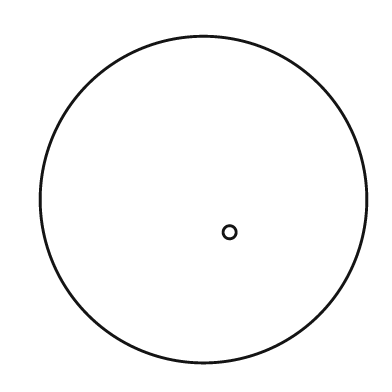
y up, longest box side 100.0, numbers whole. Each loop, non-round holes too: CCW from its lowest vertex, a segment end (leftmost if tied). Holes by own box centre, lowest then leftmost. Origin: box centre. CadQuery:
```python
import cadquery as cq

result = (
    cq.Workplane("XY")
    .moveTo(0.0, 0.0)
    .circle(50.0)
    .moveTo(8.0, -10.0)
    .circle(2.0)
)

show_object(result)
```